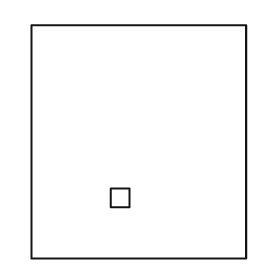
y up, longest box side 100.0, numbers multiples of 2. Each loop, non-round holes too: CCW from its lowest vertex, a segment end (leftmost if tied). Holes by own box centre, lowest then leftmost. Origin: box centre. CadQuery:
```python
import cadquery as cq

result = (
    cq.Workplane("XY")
    .moveTo(-46.0, -50.0)
    .lineTo(46.0, -50.0)
    .lineTo(46.0, 50.0)
    .lineTo(-46.0, 50.0)
    .close()
    .moveTo(-12.0, -28.0)
    .lineTo(-4.0, -28.0)
    .lineTo(-4.0, -20.0)
    .lineTo(-12.0, -20.0)
    .close()
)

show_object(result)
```